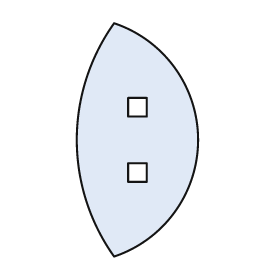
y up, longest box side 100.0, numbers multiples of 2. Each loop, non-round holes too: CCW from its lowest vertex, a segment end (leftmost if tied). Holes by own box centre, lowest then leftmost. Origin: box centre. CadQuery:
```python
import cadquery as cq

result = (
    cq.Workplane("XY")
    .moveTo(-10.0, -50.0)
    .threePointArc((26.0, 0.0), (-10.0, 50.0))
    .threePointArc((-26.0, 0.0), (-10.0, -50.0))
    .close()
    .moveTo(-4.0, -18.0)
    .lineTo(4.0, -18.0)
    .lineTo(4.0, -10.0)
    .lineTo(-4.0, -10.0)
    .close()
    .moveTo(-4.0, 10.0)
    .lineTo(4.0, 10.0)
    .lineTo(4.0, 18.0)
    .lineTo(-4.0, 18.0)
    .close()
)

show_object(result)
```